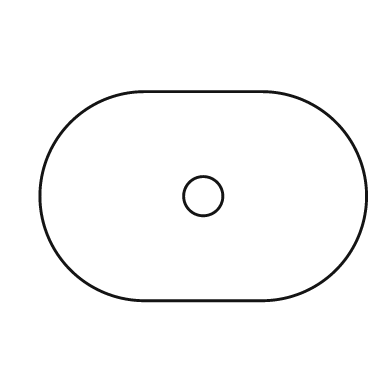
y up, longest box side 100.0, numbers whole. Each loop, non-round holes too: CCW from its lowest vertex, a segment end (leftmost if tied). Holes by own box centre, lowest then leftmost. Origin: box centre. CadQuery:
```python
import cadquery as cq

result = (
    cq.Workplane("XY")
    .moveTo(-18.0, -32.0)
    .lineTo(18.0, -32.0)
    .threePointArc((50.0, 0.0), (18.0, 32.0))
    .lineTo(-18.0, 32.0)
    .threePointArc((-50.0, 0.0), (-18.0, -32.0))
    .close()
    .moveTo(0.0, 0.0)
    .circle(6.0)
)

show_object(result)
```